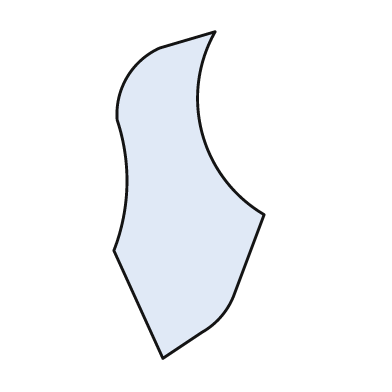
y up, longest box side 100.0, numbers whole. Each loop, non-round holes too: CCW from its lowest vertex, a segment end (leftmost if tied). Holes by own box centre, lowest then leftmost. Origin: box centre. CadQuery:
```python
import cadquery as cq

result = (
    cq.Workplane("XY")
    .moveTo(-8.0, -50.0)
    .lineTo(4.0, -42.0)
    .threePointArc((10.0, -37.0), (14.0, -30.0))
    .lineTo(23.0, -6.0)
    .threePointArc((4.0, 19.0), (8.0, 50.0))
    .lineTo(-9.0, 45.0)
    .threePointArc((-19.0, 36.0), (-22.0, 23.0))
    .threePointArc((-19.0, 3.0), (-23.0, -17.0))
    .close()
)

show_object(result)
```